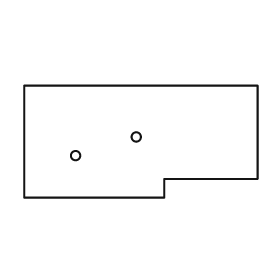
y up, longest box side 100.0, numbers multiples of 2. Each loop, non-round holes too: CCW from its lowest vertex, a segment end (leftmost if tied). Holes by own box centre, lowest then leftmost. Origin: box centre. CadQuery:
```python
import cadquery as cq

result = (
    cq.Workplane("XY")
    .moveTo(-50.0, -24.0)
    .lineTo(10.0, -24.0)
    .lineTo(10.0, -16.0)
    .lineTo(50.0, -16.0)
    .lineTo(50.0, 24.0)
    .lineTo(-50.0, 24.0)
    .close()
    .moveTo(-28.0, -6.0)
    .circle(2.0)
    .moveTo(-2.0, 2.0)
    .circle(2.0)
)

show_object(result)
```